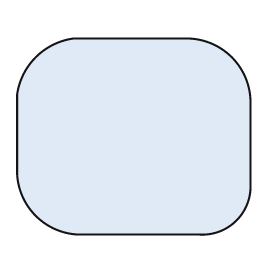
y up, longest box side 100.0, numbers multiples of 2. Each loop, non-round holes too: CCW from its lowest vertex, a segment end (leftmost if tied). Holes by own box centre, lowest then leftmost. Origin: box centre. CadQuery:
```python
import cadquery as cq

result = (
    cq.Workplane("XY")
    .moveTo(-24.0, -42.0)
    .lineTo(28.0, -42.0)
    .threePointArc((44.0, -36.0), (50.0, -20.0))
    .lineTo(50.0, 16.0)
    .threePointArc((42.0, 34.0), (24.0, 42.0))
    .lineTo(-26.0, 42.0)
    .threePointArc((-42.0, 34.0), (-50.0, 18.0))
    .lineTo(-50.0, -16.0)
    .threePointArc((-42.0, -34.0), (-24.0, -42.0))
    .close()
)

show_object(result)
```